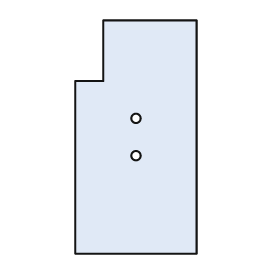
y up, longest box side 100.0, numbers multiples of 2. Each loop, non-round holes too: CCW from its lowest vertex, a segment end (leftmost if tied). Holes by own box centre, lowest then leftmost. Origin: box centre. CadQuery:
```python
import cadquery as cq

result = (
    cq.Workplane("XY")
    .moveTo(-26.0, -50.0)
    .lineTo(26.0, -50.0)
    .lineTo(26.0, 50.0)
    .lineTo(-14.0, 50.0)
    .lineTo(-14.0, 24.0)
    .lineTo(-26.0, 24.0)
    .close()
    .moveTo(0.0, -8.0)
    .circle(2.0)
    .moveTo(0.0, 8.0)
    .circle(2.0)
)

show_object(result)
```